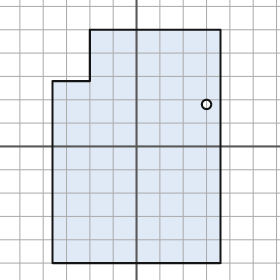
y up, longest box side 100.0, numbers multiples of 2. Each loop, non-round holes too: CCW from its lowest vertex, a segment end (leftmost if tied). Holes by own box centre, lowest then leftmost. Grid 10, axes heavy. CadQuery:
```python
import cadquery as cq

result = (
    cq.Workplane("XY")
    .moveTo(-36.0, -50.0)
    .lineTo(36.0, -50.0)
    .lineTo(36.0, 50.0)
    .lineTo(-20.0, 50.0)
    .lineTo(-20.0, 28.0)
    .lineTo(-36.0, 28.0)
    .close()
    .moveTo(30.0, 18.0)
    .circle(2.0)
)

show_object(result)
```